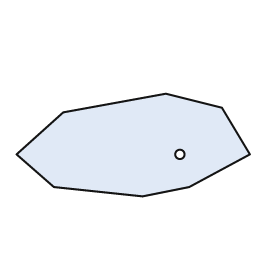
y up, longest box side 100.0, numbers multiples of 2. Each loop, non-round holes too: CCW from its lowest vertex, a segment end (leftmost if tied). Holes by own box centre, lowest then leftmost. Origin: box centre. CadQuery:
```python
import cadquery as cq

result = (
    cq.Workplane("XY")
    .moveTo(4.0, -22.0)
    .lineTo(24.0, -18.0)
    .lineTo(50.0, -4.0)
    .lineTo(38.0, 16.0)
    .lineTo(14.0, 22.0)
    .lineTo(-30.0, 14.0)
    .lineTo(-50.0, -4.0)
    .lineTo(-34.0, -18.0)
    .close()
    .moveTo(20.0, -4.0)
    .circle(2.0)
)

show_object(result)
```